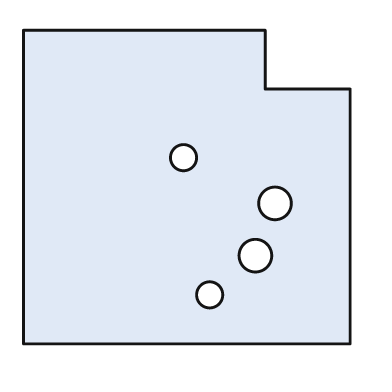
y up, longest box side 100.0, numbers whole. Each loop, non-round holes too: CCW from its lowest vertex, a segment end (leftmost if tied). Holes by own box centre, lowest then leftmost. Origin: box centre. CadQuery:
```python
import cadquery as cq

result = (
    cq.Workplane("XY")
    .moveTo(-50.0, -48.0)
    .lineTo(50.0, -48.0)
    .lineTo(50.0, 30.0)
    .lineTo(24.0, 30.0)
    .lineTo(24.0, 48.0)
    .lineTo(-50.0, 48.0)
    .close()
    .moveTo(7.0, -33.0)
    .circle(4.0)
    .moveTo(21.0, -21.0)
    .circle(5.0)
    .moveTo(27.0, -5.0)
    .circle(5.0)
    .moveTo(-1.0, 9.0)
    .circle(4.0)
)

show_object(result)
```